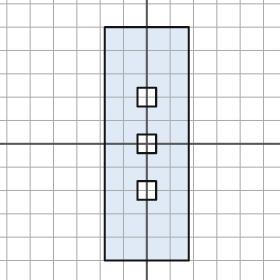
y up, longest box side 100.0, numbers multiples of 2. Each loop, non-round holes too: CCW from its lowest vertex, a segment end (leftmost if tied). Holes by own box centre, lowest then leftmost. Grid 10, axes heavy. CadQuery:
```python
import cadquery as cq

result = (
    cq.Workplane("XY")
    .moveTo(-18.0, -50.0)
    .lineTo(18.0, -50.0)
    .lineTo(18.0, 50.0)
    .lineTo(-18.0, 50.0)
    .close()
    .moveTo(-4.0, -24.0)
    .lineTo(4.0, -24.0)
    .lineTo(4.0, -16.0)
    .lineTo(-4.0, -16.0)
    .close()
    .moveTo(-4.0, -4.0)
    .lineTo(4.0, -4.0)
    .lineTo(4.0, 4.0)
    .lineTo(-4.0, 4.0)
    .close()
    .moveTo(-4.0, 16.0)
    .lineTo(4.0, 16.0)
    .lineTo(4.0, 24.0)
    .lineTo(-4.0, 24.0)
    .close()
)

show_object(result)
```